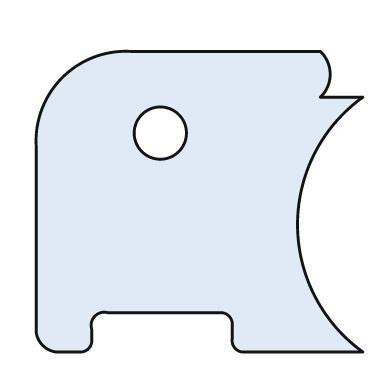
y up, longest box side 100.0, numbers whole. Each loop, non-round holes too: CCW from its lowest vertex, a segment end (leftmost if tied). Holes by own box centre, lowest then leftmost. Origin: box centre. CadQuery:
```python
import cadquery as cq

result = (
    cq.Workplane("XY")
    .moveTo(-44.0, -46.0)
    .lineTo(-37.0, -46.0)
    .threePointArc((-34.0, -45.0), (-33.0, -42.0))
    .lineTo(-33.0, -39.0)
    .threePointArc((-32.0, -35.0), (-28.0, -34.0))
    .lineTo(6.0, -34.0)
    .threePointArc((9.0, -35.0), (10.0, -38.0))
    .lineTo(10.0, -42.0)
    .threePointArc((11.0, -45.0), (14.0, -46.0))
    .lineTo(50.0, -46.0)
    .threePointArc((30.0, -7.0), (50.0, 32.0))
    .lineTo(37.0, 32.0)
    .threePointArc((40.0, 39.0), (37.0, 46.0))
    .lineTo(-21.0, 46.0)
    .threePointArc((-42.0, 38.0), (-50.0, 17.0))
    .lineTo(-50.0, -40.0)
    .threePointArc((-48.0, -44.0), (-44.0, -46.0))
    .close()
    .moveTo(-12.0, 21.0)
    .circle(8.0)
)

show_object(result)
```